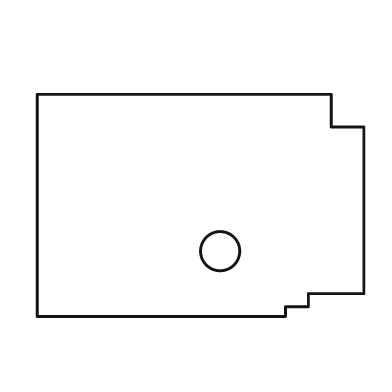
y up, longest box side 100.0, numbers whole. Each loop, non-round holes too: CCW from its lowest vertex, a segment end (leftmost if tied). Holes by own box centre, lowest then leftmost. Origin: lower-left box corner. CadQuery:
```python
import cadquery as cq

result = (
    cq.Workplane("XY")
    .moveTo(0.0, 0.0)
    .lineTo(76.0, 0.0)
    .lineTo(76.0, 3.0)
    .lineTo(83.0, 3.0)
    .lineTo(83.0, 7.0)
    .lineTo(100.0, 7.0)
    .lineTo(100.0, 58.0)
    .lineTo(90.0, 58.0)
    .lineTo(90.0, 68.0)
    .lineTo(0.0, 68.0)
    .close()
    .moveTo(56.0, 20.0)
    .circle(6.0)
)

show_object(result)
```